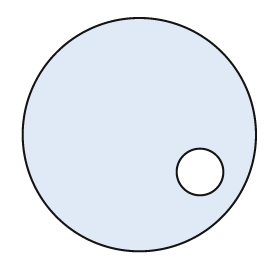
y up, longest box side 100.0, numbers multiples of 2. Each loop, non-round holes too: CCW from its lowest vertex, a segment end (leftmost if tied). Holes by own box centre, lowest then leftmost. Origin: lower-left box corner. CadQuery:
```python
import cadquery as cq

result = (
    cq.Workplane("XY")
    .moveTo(50.0, 50.0)
    .circle(50.0)
    .moveTo(76.0, 34.0)
    .circle(10.0)
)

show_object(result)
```